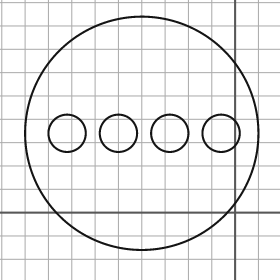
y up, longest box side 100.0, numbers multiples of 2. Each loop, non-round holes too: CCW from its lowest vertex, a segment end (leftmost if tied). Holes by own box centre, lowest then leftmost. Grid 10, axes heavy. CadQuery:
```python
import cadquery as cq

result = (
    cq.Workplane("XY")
    .moveTo(-40.0, 34.0)
    .circle(50.0)
    .moveTo(-72.0, 34.0)
    .circle(8.0)
    .moveTo(-50.0, 34.0)
    .circle(8.0)
    .moveTo(-28.0, 34.0)
    .circle(8.0)
    .moveTo(-6.0, 34.0)
    .circle(8.0)
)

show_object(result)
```